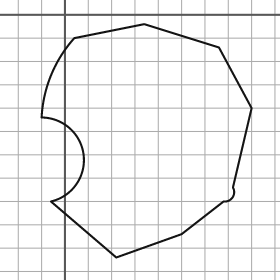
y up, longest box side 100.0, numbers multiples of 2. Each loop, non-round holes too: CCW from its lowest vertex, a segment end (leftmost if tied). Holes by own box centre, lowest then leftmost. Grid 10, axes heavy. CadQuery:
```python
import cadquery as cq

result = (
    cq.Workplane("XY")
    .moveTo(22.0, -104.0)
    .lineTo(50.0, -94.0)
    .lineTo(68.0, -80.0)
    .threePointArc((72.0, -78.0), (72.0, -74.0))
    .lineTo(80.0, -40.0)
    .lineTo(66.0, -14.0)
    .lineTo(34.0, -4.0)
    .lineTo(4.0, -10.0)
    .threePointArc((-6.0, -26.0), (-10.0, -44.0))
    .threePointArc((8.0, -60.0), (-6.0, -80.0))
    .close()
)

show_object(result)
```